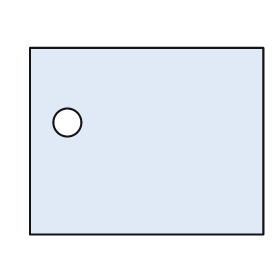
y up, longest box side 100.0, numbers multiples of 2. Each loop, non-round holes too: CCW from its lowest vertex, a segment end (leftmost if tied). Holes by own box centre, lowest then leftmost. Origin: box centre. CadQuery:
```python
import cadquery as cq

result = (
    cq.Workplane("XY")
    .moveTo(-50.0, -40.0)
    .lineTo(50.0, -40.0)
    .lineTo(50.0, 40.0)
    .lineTo(-50.0, 40.0)
    .close()
    .moveTo(-34.0, 8.0)
    .circle(6.0)
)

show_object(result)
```